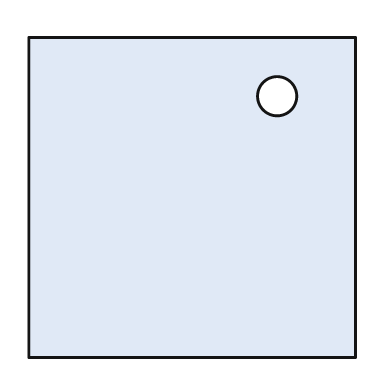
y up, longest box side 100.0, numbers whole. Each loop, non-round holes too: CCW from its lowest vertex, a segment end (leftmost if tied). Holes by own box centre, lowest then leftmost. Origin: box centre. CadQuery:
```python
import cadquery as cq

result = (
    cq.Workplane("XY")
    .moveTo(-50.0, -49.0)
    .lineTo(50.0, -49.0)
    .lineTo(50.0, 49.0)
    .lineTo(-50.0, 49.0)
    .close()
    .moveTo(26.0, 31.0)
    .circle(6.0)
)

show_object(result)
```